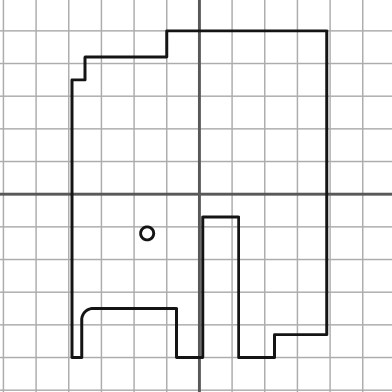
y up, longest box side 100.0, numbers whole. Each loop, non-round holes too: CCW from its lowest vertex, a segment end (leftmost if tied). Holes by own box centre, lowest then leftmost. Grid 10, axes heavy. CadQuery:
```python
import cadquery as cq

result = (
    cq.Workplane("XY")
    .moveTo(-39.0, -50.0)
    .lineTo(-36.0, -50.0)
    .lineTo(-36.0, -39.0)
    .threePointArc((-35.0, -36.0), (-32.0, -35.0))
    .lineTo(-7.0, -35.0)
    .lineTo(-7.0, -50.0)
    .lineTo(1.0, -50.0)
    .lineTo(1.0, -7.0)
    .lineTo(12.0, -7.0)
    .lineTo(12.0, -50.0)
    .lineTo(23.0, -50.0)
    .lineTo(23.0, -43.0)
    .lineTo(39.0, -43.0)
    .lineTo(39.0, 50.0)
    .lineTo(-10.0, 50.0)
    .lineTo(-10.0, 42.0)
    .lineTo(-35.0, 42.0)
    .lineTo(-35.0, 35.0)
    .lineTo(-39.0, 35.0)
    .close()
    .moveTo(-16.0, -12.0)
    .circle(2.0)
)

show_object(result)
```